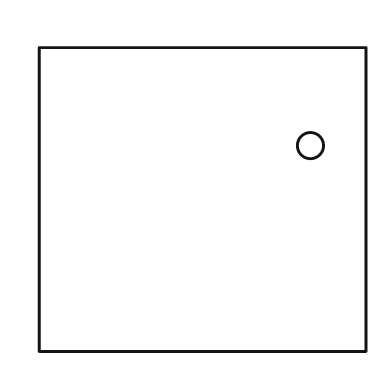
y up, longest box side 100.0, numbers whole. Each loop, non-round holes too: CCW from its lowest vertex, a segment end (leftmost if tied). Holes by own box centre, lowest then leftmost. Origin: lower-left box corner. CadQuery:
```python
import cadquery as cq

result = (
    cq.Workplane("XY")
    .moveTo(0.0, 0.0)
    .lineTo(100.0, 0.0)
    .lineTo(100.0, 93.0)
    .lineTo(0.0, 93.0)
    .close()
    .moveTo(83.0, 63.0)
    .circle(4.0)
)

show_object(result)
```